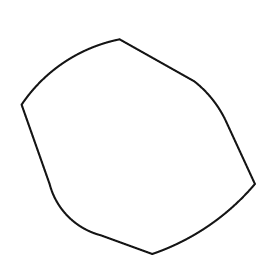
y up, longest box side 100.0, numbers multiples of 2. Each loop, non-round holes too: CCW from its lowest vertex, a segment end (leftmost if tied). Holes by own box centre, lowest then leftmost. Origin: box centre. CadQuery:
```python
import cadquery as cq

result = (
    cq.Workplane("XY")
    .moveTo(6.0, -46.0)
    .threePointArc((30.0, -34.0), (50.0, -16.0))
    .lineTo(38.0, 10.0)
    .threePointArc((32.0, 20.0), (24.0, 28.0))
    .lineTo(-8.0, 46.0)
    .threePointArc((-32.0, 36.0), (-50.0, 18.0))
    .lineTo(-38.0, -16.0)
    .threePointArc((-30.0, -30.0), (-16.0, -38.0))
    .close()
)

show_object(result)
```